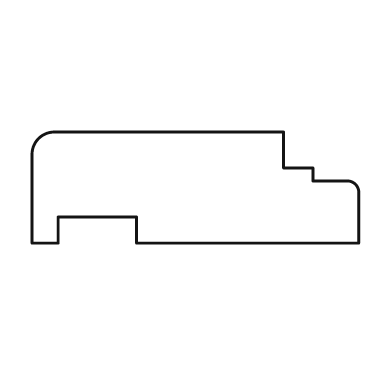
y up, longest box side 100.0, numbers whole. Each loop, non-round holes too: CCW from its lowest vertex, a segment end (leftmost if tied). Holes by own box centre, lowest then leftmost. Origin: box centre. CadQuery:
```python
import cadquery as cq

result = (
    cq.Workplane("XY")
    .moveTo(-50.0, -17.0)
    .lineTo(-42.0, -17.0)
    .lineTo(-42.0, -9.0)
    .lineTo(-18.0, -9.0)
    .lineTo(-18.0, -17.0)
    .lineTo(50.0, -17.0)
    .lineTo(50.0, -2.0)
    .threePointArc((49.0, 1.0), (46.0, 2.0))
    .lineTo(36.0, 2.0)
    .lineTo(36.0, 6.0)
    .lineTo(27.0, 6.0)
    .lineTo(27.0, 17.0)
    .lineTo(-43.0, 17.0)
    .threePointArc((-48.0, 15.0), (-50.0, 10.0))
    .close()
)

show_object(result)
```